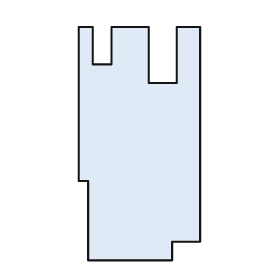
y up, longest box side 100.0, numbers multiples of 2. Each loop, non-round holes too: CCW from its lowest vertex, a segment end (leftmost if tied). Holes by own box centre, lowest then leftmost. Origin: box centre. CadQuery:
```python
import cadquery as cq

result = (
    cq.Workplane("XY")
    .moveTo(-22.0, -50.0)
    .lineTo(14.0, -50.0)
    .lineTo(14.0, -42.0)
    .lineTo(26.0, -42.0)
    .lineTo(26.0, 50.0)
    .lineTo(16.0, 50.0)
    .lineTo(16.0, 26.0)
    .lineTo(4.0, 26.0)
    .lineTo(4.0, 50.0)
    .lineTo(-12.0, 50.0)
    .lineTo(-12.0, 34.0)
    .lineTo(-20.0, 34.0)
    .lineTo(-20.0, 50.0)
    .lineTo(-26.0, 50.0)
    .lineTo(-26.0, -16.0)
    .lineTo(-22.0, -16.0)
    .close()
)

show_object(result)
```